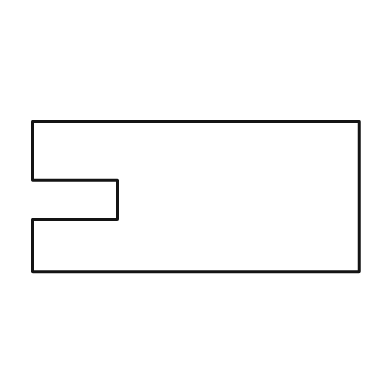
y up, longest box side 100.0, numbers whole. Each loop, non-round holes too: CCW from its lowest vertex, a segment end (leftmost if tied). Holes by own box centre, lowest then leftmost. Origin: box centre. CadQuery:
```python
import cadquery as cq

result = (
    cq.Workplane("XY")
    .moveTo(-50.0, -23.0)
    .lineTo(50.0, -23.0)
    .lineTo(50.0, 23.0)
    .lineTo(-50.0, 23.0)
    .lineTo(-50.0, 5.0)
    .lineTo(-24.0, 5.0)
    .lineTo(-24.0, -7.0)
    .lineTo(-50.0, -7.0)
    .close()
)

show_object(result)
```